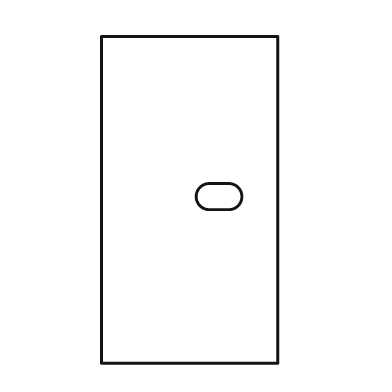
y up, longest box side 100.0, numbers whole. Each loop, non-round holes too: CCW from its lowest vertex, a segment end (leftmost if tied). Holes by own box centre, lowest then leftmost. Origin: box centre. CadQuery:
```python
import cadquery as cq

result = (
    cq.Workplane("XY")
    .moveTo(-27.0, -50.0)
    .lineTo(27.0, -50.0)
    .lineTo(27.0, 50.0)
    .lineTo(-27.0, 50.0)
    .close()
    .moveTo(6.0, -3.0)
    .lineTo(12.0, -3.0)
    .threePointArc((16.0, 1.0), (12.0, 5.0))
    .lineTo(6.0, 5.0)
    .threePointArc((2.0, 1.0), (6.0, -3.0))
    .close()
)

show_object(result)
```